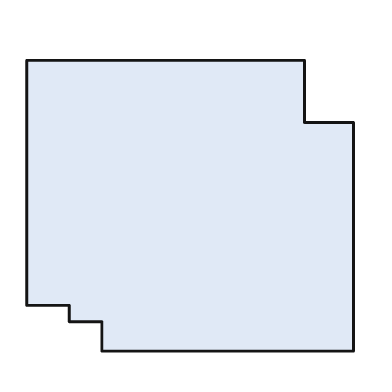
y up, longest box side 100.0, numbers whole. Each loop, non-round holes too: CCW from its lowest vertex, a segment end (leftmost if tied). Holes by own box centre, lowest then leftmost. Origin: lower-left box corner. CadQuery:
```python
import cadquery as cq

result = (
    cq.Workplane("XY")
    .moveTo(23.0, 0.0)
    .lineTo(100.0, 0.0)
    .lineTo(100.0, 70.0)
    .lineTo(85.0, 70.0)
    .lineTo(85.0, 89.0)
    .lineTo(0.0, 89.0)
    .lineTo(0.0, 14.0)
    .lineTo(13.0, 14.0)
    .lineTo(13.0, 9.0)
    .lineTo(23.0, 9.0)
    .close()
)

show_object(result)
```